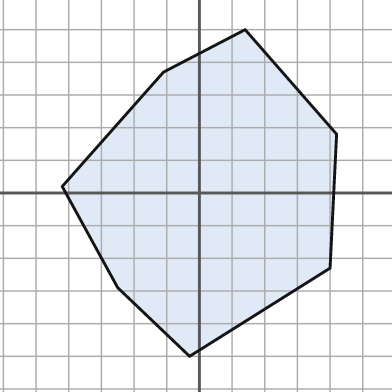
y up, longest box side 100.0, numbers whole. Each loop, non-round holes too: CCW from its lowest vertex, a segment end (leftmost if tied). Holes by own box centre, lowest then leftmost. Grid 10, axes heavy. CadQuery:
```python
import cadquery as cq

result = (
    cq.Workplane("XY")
    .moveTo(-3.0, -50.0)
    .lineTo(40.0, -23.0)
    .lineTo(42.0, 18.0)
    .lineTo(14.0, 50.0)
    .lineTo(-11.0, 37.0)
    .lineTo(-42.0, 2.0)
    .lineTo(-25.0, -29.0)
    .close()
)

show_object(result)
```